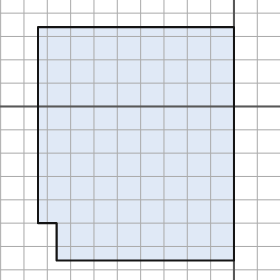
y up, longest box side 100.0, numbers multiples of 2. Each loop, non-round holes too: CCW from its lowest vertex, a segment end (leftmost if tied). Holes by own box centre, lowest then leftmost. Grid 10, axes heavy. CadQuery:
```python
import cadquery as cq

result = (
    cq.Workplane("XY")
    .moveTo(-76.0, -66.0)
    .lineTo(0.0, -66.0)
    .lineTo(0.0, 34.0)
    .lineTo(-84.0, 34.0)
    .lineTo(-84.0, -50.0)
    .lineTo(-76.0, -50.0)
    .close()
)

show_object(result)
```